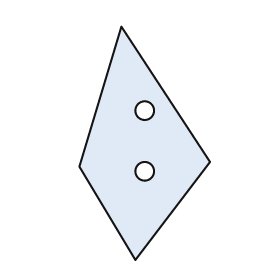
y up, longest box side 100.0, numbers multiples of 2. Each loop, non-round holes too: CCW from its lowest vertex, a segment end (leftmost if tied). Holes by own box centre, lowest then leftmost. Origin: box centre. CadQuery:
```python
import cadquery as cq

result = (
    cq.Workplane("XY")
    .moveTo(-4.0, -50.0)
    .lineTo(28.0, -8.0)
    .lineTo(-10.0, 50.0)
    .lineTo(-28.0, -10.0)
    .close()
    .moveTo(0.0, -12.0)
    .circle(4.0)
    .moveTo(0.0, 14.0)
    .circle(4.0)
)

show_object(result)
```